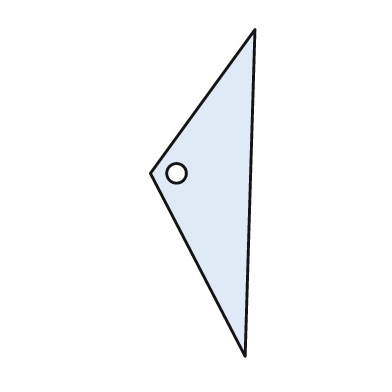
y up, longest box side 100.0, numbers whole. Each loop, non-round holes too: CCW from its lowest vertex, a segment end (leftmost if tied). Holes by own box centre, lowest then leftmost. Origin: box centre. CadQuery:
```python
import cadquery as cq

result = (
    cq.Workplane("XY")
    .moveTo(13.0, -50.0)
    .lineTo(16.0, 50.0)
    .lineTo(-16.0, 6.0)
    .close()
    .moveTo(-8.0, 6.0)
    .circle(3.0)
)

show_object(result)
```